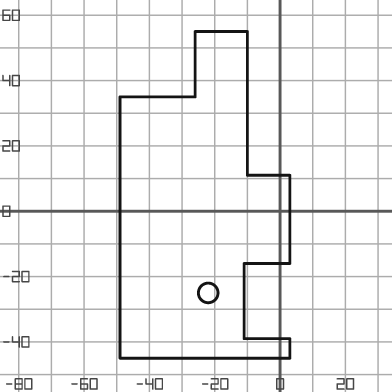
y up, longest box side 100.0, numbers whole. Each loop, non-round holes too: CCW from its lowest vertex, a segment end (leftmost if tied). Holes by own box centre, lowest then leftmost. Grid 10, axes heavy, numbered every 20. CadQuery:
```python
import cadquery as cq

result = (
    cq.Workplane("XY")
    .moveTo(-49.0, -45.0)
    .lineTo(3.0, -45.0)
    .lineTo(3.0, -39.0)
    .lineTo(-11.0, -39.0)
    .lineTo(-11.0, -16.0)
    .lineTo(3.0, -16.0)
    .lineTo(3.0, 11.0)
    .lineTo(-10.0, 11.0)
    .lineTo(-10.0, 55.0)
    .lineTo(-26.0, 55.0)
    .lineTo(-26.0, 35.0)
    .lineTo(-49.0, 35.0)
    .close()
    .moveTo(-22.0, -25.0)
    .circle(3.0)
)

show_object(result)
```